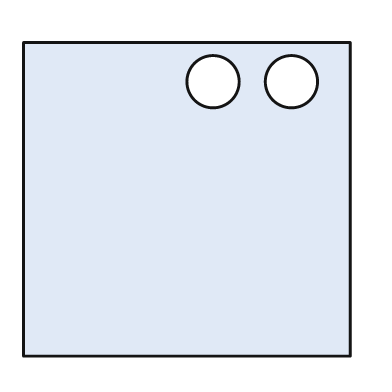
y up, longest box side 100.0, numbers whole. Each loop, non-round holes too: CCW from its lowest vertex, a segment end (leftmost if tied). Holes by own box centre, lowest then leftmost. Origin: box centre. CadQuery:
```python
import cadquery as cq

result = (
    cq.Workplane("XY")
    .moveTo(-50.0, -48.0)
    .lineTo(50.0, -48.0)
    .lineTo(50.0, 48.0)
    .lineTo(-50.0, 48.0)
    .close()
    .moveTo(8.0, 36.0)
    .circle(8.0)
    .moveTo(32.0, 36.0)
    .circle(8.0)
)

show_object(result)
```